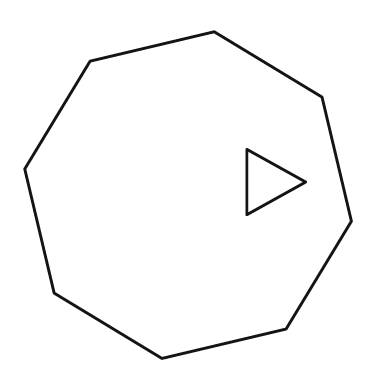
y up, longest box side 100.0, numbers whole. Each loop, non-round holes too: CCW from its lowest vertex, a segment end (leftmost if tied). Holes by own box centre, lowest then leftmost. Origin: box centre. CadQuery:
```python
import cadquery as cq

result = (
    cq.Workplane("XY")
    .moveTo(-8.0, -50.0)
    .lineTo(30.0, -41.0)
    .lineTo(50.0, -8.0)
    .lineTo(41.0, 30.0)
    .lineTo(8.0, 50.0)
    .lineTo(-30.0, 41.0)
    .lineTo(-50.0, 8.0)
    .lineTo(-41.0, -30.0)
    .close()
    .moveTo(18.0, -6.0)
    .lineTo(36.0, 4.0)
    .lineTo(18.0, 14.0)
    .close()
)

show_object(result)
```